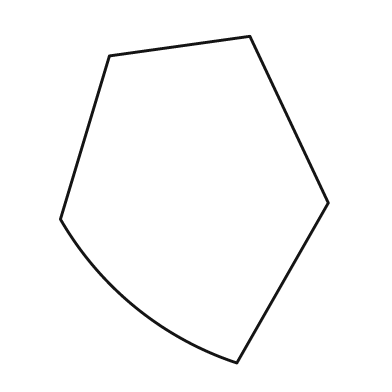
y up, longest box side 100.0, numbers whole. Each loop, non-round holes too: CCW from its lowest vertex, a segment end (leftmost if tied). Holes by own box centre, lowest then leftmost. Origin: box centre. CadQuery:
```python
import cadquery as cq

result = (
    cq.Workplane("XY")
    .moveTo(13.0, -50.0)
    .lineTo(41.0, -1.0)
    .lineTo(17.0, 50.0)
    .lineTo(-26.0, 44.0)
    .lineTo(-41.0, -6.0)
    .threePointArc((-18.0, -33.0), (13.0, -50.0))
    .close()
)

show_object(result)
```